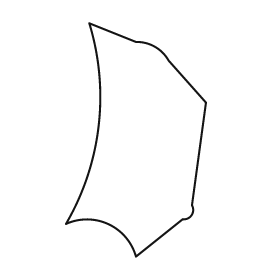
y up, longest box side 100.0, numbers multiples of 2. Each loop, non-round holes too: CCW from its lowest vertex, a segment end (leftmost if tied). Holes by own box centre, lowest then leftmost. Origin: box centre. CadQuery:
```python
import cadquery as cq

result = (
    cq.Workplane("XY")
    .moveTo(0.0, -50.0)
    .lineTo(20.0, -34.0)
    .threePointArc((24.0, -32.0), (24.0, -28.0))
    .lineTo(30.0, 16.0)
    .lineTo(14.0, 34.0)
    .threePointArc((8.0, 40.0), (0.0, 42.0))
    .lineTo(-20.0, 50.0)
    .threePointArc((-16.0, 6.0), (-30.0, -36.0))
    .threePointArc((-12.0, -36.0), (0.0, -50.0))
    .close()
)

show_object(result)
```